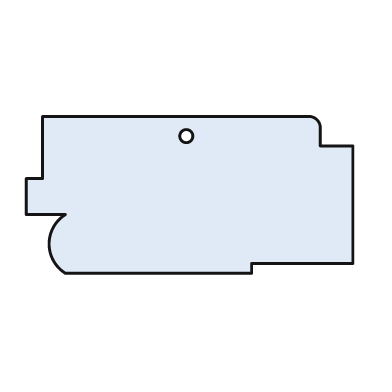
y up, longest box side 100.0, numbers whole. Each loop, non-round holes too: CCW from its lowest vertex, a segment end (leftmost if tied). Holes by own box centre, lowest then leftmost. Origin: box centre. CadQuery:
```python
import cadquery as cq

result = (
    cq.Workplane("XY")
    .moveTo(-38.0, -24.0)
    .lineTo(19.0, -24.0)
    .lineTo(19.0, -21.0)
    .lineTo(50.0, -21.0)
    .lineTo(50.0, 15.0)
    .lineTo(40.0, 15.0)
    .lineTo(40.0, 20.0)
    .threePointArc((39.0, 23.0), (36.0, 24.0))
    .lineTo(-45.0, 24.0)
    .lineTo(-45.0, 5.0)
    .lineTo(-50.0, 5.0)
    .lineTo(-50.0, -6.0)
    .lineTo(-38.0, -6.0)
    .threePointArc((-43.0, -15.0), (-38.0, -24.0))
    .close()
    .moveTo(-1.0, 18.0)
    .circle(2.0)
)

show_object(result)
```